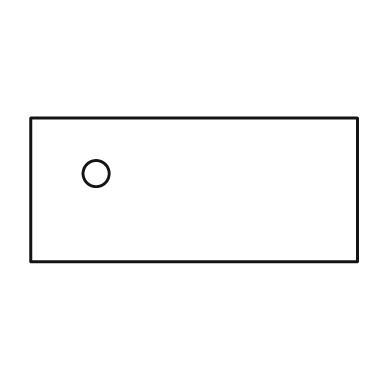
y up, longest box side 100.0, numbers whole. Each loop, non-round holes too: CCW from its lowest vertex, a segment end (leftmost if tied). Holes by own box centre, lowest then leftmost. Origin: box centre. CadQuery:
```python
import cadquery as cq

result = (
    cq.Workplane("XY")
    .moveTo(-50.0, -22.0)
    .lineTo(50.0, -22.0)
    .lineTo(50.0, 22.0)
    .lineTo(-50.0, 22.0)
    .close()
    .moveTo(-30.0, 5.0)
    .circle(4.0)
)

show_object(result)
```